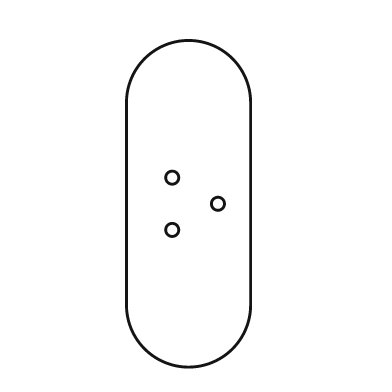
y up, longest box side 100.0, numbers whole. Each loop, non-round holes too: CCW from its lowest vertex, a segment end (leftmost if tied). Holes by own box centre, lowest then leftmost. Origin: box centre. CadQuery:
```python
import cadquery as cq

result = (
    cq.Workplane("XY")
    .moveTo(-19.0, -31.0)
    .threePointArc((0.0, -50.0), (19.0, -31.0))
    .lineTo(19.0, 31.0)
    .threePointArc((0.0, 50.0), (-19.0, 31.0))
    .close()
    .moveTo(-5.0, -8.0)
    .circle(2.0)
    .moveTo(9.0, 0.0)
    .circle(2.0)
    .moveTo(-5.0, 8.0)
    .circle(2.0)
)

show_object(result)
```